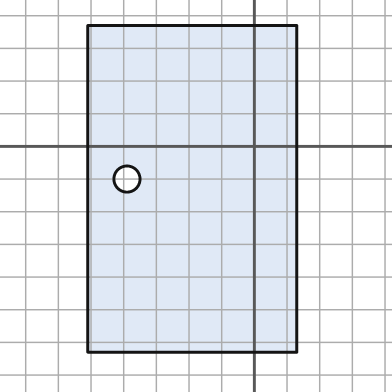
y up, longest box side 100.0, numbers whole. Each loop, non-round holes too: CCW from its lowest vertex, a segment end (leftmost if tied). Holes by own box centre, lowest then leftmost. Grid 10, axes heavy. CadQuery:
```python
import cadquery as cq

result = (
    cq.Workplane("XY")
    .moveTo(-51.0, -63.0)
    .lineTo(13.0, -63.0)
    .lineTo(13.0, 37.0)
    .lineTo(-51.0, 37.0)
    .close()
    .moveTo(-39.0, -10.0)
    .circle(4.0)
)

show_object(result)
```